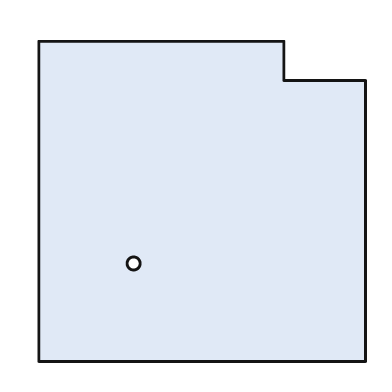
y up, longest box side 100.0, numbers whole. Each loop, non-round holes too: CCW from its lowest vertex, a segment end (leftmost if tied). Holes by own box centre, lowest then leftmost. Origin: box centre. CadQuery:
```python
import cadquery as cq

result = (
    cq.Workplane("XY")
    .moveTo(-50.0, -49.0)
    .lineTo(50.0, -49.0)
    .lineTo(50.0, 37.0)
    .lineTo(25.0, 37.0)
    .lineTo(25.0, 49.0)
    .lineTo(-50.0, 49.0)
    .close()
    .moveTo(-21.0, -19.0)
    .circle(2.0)
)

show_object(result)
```